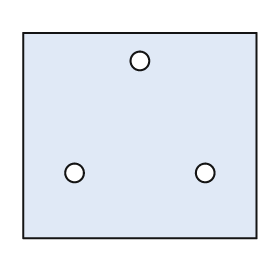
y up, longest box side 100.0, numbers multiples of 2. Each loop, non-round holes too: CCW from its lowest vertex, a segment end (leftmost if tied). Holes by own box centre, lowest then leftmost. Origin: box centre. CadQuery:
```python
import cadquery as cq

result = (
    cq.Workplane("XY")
    .moveTo(-50.0, -44.0)
    .lineTo(50.0, -44.0)
    .lineTo(50.0, 44.0)
    .lineTo(-50.0, 44.0)
    .close()
    .moveTo(-28.0, -16.0)
    .circle(4.0)
    .moveTo(28.0, -16.0)
    .circle(4.0)
    .moveTo(0.0, 32.0)
    .circle(4.0)
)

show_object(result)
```